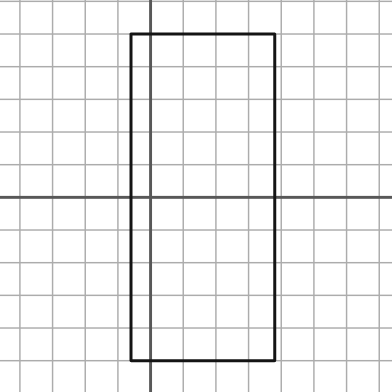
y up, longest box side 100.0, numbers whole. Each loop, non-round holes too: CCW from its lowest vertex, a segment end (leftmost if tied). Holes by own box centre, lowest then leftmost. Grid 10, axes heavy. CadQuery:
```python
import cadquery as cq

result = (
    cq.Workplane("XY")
    .moveTo(-6.0, -50.0)
    .lineTo(38.0, -50.0)
    .lineTo(38.0, 50.0)
    .lineTo(-6.0, 50.0)
    .close()
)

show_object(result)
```